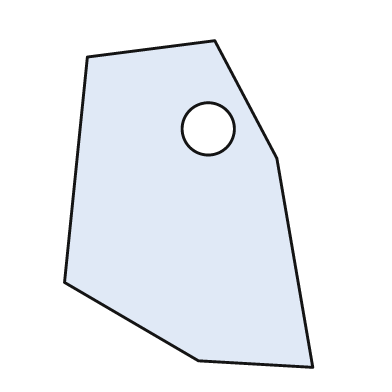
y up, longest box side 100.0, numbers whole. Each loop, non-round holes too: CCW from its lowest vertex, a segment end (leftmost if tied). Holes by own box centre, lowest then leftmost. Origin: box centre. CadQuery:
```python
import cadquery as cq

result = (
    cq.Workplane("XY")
    .moveTo(38.0, -50.0)
    .lineTo(27.0, 14.0)
    .lineTo(8.0, 50.0)
    .lineTo(-31.0, 45.0)
    .lineTo(-38.0, -24.0)
    .lineTo(3.0, -48.0)
    .close()
    .moveTo(6.0, 23.0)
    .circle(8.0)
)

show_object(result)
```